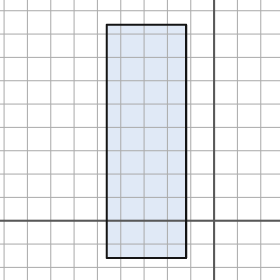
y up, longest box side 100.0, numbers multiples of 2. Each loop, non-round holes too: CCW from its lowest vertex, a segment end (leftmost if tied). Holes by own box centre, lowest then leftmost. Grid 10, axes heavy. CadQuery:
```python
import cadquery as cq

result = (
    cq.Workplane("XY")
    .moveTo(-46.0, -16.0)
    .lineTo(-12.0, -16.0)
    .lineTo(-12.0, 84.0)
    .lineTo(-46.0, 84.0)
    .close()
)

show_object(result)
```